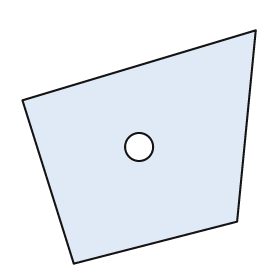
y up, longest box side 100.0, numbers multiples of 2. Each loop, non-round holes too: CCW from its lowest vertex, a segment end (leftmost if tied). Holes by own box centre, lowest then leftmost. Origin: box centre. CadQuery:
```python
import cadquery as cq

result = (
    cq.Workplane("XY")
    .moveTo(-28.0, -50.0)
    .lineTo(42.0, -32.0)
    .lineTo(50.0, 50.0)
    .lineTo(-50.0, 20.0)
    .close()
    .moveTo(0.0, 0.0)
    .circle(6.0)
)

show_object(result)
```